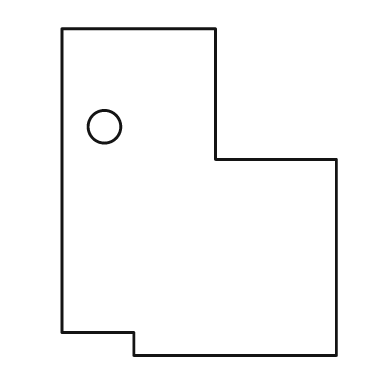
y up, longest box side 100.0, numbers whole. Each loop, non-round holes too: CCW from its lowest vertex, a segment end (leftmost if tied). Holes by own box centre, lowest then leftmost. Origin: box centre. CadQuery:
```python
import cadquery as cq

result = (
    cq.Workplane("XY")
    .moveTo(-20.0, -50.0)
    .lineTo(42.0, -50.0)
    .lineTo(42.0, 10.0)
    .lineTo(5.0, 10.0)
    .lineTo(5.0, 50.0)
    .lineTo(-42.0, 50.0)
    .lineTo(-42.0, -43.0)
    .lineTo(-20.0, -43.0)
    .close()
    .moveTo(-29.0, 20.0)
    .circle(5.0)
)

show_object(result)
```